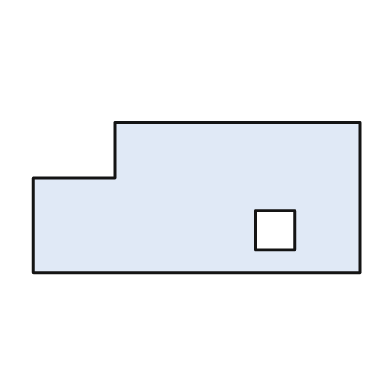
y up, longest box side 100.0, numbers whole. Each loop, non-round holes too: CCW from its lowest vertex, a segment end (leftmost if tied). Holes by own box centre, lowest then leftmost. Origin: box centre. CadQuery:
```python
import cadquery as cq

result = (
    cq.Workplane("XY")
    .moveTo(-50.0, -23.0)
    .lineTo(50.0, -23.0)
    .lineTo(50.0, 23.0)
    .lineTo(-25.0, 23.0)
    .lineTo(-25.0, 6.0)
    .lineTo(-50.0, 6.0)
    .close()
    .moveTo(18.0, -16.0)
    .lineTo(30.0, -16.0)
    .lineTo(30.0, -4.0)
    .lineTo(18.0, -4.0)
    .close()
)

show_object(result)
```